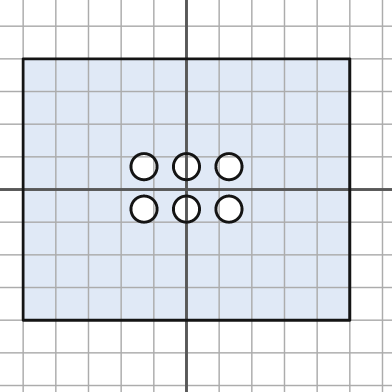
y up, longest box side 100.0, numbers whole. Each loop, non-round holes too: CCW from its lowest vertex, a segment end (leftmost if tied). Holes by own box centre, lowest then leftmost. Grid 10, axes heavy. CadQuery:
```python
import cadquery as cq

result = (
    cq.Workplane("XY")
    .moveTo(-50.0, -40.0)
    .lineTo(50.0, -40.0)
    .lineTo(50.0, 40.0)
    .lineTo(-50.0, 40.0)
    .close()
    .moveTo(-13.0, -6.0)
    .circle(4.0)
    .moveTo(0.0, -6.0)
    .circle(4.0)
    .moveTo(13.0, -6.0)
    .circle(4.0)
    .moveTo(-13.0, 7.0)
    .circle(4.0)
    .moveTo(0.0, 7.0)
    .circle(4.0)
    .moveTo(13.0, 7.0)
    .circle(4.0)
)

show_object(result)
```